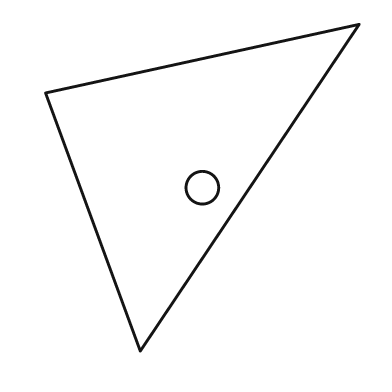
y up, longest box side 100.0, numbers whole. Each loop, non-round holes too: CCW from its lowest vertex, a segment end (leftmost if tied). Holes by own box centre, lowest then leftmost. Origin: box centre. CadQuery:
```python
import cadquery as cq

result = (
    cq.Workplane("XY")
    .moveTo(-19.0, -50.0)
    .lineTo(48.0, 50.0)
    .lineTo(-48.0, 29.0)
    .close()
    .moveTo(0.0, 0.0)
    .circle(5.0)
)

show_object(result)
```